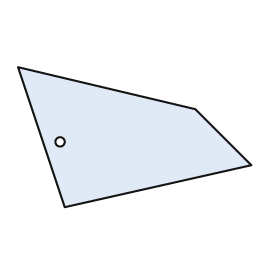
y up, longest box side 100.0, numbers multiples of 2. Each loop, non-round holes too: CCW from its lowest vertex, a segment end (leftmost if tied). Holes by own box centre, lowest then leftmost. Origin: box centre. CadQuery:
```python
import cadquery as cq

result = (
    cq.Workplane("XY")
    .moveTo(-30.0, -30.0)
    .lineTo(50.0, -12.0)
    .lineTo(26.0, 12.0)
    .lineTo(-50.0, 30.0)
    .close()
    .moveTo(-32.0, -2.0)
    .circle(2.0)
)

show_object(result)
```